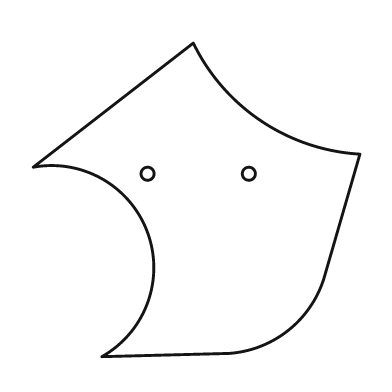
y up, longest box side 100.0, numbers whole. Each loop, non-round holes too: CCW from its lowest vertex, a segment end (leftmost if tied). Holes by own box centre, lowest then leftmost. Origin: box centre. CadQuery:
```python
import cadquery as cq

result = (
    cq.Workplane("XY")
    .moveTo(-29.0, -48.0)
    .lineTo(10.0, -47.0)
    .threePointArc((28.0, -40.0), (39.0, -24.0))
    .lineTo(50.0, 14.0)
    .threePointArc((20.0, 24.0), (-1.0, 48.0))
    .lineTo(-50.0, 10.0)
    .threePointArc((-15.0, -10.0), (-29.0, -48.0))
    .close()
    .moveTo(-15.0, 8.0)
    .circle(2.0)
    .moveTo(16.0, 8.0)
    .circle(2.0)
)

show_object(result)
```